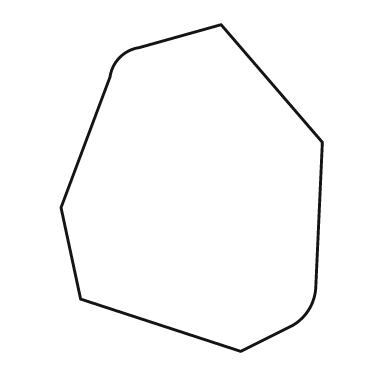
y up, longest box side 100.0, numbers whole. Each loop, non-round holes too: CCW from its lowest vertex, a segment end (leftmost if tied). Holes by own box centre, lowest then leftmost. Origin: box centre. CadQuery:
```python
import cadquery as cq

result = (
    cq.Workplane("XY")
    .moveTo(15.0, -50.0)
    .lineTo(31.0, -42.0)
    .threePointArc((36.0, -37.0), (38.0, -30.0))
    .lineTo(40.0, 14.0)
    .lineTo(9.0, 50.0)
    .lineTo(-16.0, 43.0)
    .threePointArc((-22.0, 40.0), (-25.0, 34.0))
    .lineTo(-40.0, -6.0)
    .lineTo(-34.0, -34.0)
    .close()
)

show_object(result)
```